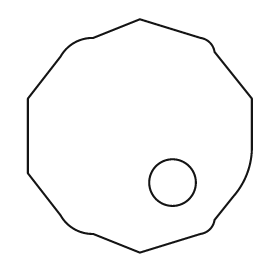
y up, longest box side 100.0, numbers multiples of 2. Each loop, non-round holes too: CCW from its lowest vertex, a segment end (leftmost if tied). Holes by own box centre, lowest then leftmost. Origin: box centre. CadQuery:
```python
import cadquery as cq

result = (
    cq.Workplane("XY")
    .moveTo(0.0, -50.0)
    .lineTo(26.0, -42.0)
    .threePointArc((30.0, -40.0), (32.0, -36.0))
    .lineTo(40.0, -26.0)
    .threePointArc((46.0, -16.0), (48.0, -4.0))
    .lineTo(48.0, 16.0)
    .lineTo(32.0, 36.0)
    .threePointArc((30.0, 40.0), (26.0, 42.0))
    .lineTo(0.0, 50.0)
    .lineTo(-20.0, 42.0)
    .threePointArc((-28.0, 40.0), (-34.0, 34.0))
    .lineTo(-48.0, 16.0)
    .lineTo(-48.0, -16.0)
    .lineTo(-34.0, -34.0)
    .threePointArc((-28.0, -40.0), (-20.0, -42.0))
    .close()
    .moveTo(14.0, -20.0)
    .circle(10.0)
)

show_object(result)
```